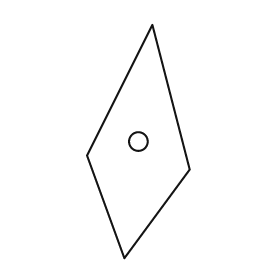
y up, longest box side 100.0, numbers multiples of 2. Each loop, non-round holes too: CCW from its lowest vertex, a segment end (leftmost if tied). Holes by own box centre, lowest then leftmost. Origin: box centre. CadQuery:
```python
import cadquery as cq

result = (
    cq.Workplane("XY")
    .moveTo(-6.0, -50.0)
    .lineTo(22.0, -12.0)
    .lineTo(6.0, 50.0)
    .lineTo(-22.0, -6.0)
    .close()
    .moveTo(0.0, 0.0)
    .circle(4.0)
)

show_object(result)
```